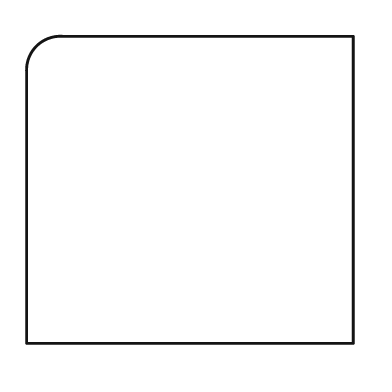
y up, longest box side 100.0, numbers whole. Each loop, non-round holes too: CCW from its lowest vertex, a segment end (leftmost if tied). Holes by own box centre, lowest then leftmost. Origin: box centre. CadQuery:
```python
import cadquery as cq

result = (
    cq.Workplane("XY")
    .moveTo(-50.0, -47.0)
    .lineTo(50.0, -47.0)
    .lineTo(50.0, 47.0)
    .lineTo(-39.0, 47.0)
    .threePointArc((-47.0, 44.0), (-50.0, 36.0))
    .close()
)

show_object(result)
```